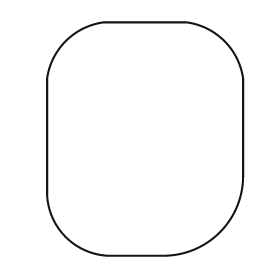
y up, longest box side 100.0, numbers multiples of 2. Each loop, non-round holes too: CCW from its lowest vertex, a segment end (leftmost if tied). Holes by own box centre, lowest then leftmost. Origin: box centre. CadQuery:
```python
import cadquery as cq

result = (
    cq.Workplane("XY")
    .moveTo(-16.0, -50.0)
    .lineTo(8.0, -50.0)
    .threePointArc((32.0, -40.0), (42.0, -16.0))
    .lineTo(42.0, 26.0)
    .threePointArc((34.0, 42.0), (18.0, 50.0))
    .lineTo(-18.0, 50.0)
    .threePointArc((-34.0, 42.0), (-42.0, 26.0))
    .lineTo(-42.0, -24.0)
    .threePointArc((-34.0, -42.0), (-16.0, -50.0))
    .close()
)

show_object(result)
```